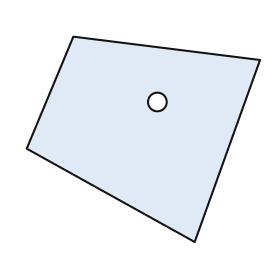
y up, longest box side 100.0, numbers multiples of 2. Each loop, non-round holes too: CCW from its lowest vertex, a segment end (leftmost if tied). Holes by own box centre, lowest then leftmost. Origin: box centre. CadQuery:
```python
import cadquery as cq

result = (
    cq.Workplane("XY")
    .moveTo(22.0, -44.0)
    .lineTo(50.0, 34.0)
    .lineTo(-30.0, 44.0)
    .lineTo(-50.0, -4.0)
    .close()
    .moveTo(6.0, 16.0)
    .circle(4.0)
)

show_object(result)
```